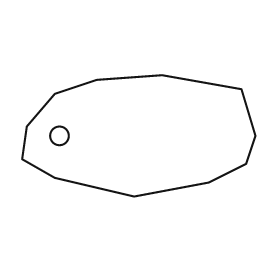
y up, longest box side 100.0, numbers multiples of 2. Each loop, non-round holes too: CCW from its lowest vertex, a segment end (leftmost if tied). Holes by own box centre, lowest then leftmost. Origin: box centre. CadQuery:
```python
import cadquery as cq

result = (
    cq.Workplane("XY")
    .moveTo(-2.0, -26.0)
    .lineTo(30.0, -20.0)
    .lineTo(46.0, -12.0)
    .lineTo(50.0, 0.0)
    .lineTo(44.0, 20.0)
    .lineTo(10.0, 26.0)
    .lineTo(-18.0, 24.0)
    .lineTo(-36.0, 18.0)
    .lineTo(-48.0, 4.0)
    .lineTo(-50.0, -10.0)
    .lineTo(-36.0, -18.0)
    .close()
    .moveTo(-34.0, 0.0)
    .circle(4.0)
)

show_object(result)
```